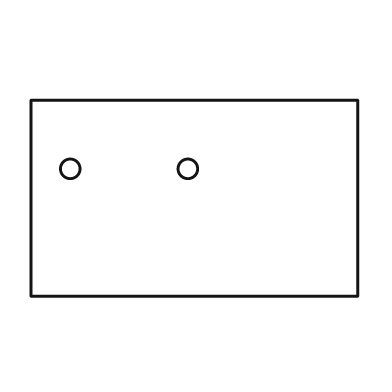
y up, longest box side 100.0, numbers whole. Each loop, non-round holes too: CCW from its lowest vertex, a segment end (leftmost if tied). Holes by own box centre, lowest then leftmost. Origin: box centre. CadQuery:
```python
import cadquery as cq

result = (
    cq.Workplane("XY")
    .moveTo(-50.0, -30.0)
    .lineTo(50.0, -30.0)
    .lineTo(50.0, 30.0)
    .lineTo(-50.0, 30.0)
    .close()
    .moveTo(-38.0, 9.0)
    .circle(3.0)
    .moveTo(-2.0, 9.0)
    .circle(3.0)
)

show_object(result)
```